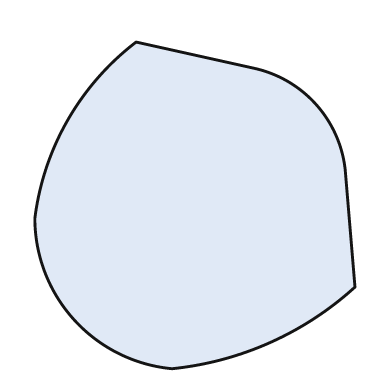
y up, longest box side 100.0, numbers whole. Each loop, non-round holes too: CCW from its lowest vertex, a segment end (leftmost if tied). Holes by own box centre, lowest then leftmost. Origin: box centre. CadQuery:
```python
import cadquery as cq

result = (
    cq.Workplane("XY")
    .moveTo(-7.0, -50.0)
    .threePointArc((23.0, -42.0), (49.0, -25.0))
    .lineTo(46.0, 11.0)
    .threePointArc((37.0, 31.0), (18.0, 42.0))
    .lineTo(-18.0, 50.0)
    .threePointArc((-39.0, 26.0), (-49.0, -4.0))
    .threePointArc((-37.0, -35.0), (-7.0, -50.0))
    .close()
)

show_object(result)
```